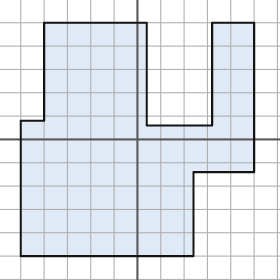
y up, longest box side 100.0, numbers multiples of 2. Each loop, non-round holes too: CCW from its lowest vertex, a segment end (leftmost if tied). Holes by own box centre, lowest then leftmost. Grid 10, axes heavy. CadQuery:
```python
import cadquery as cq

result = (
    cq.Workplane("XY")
    .moveTo(-50.0, -50.0)
    .lineTo(24.0, -50.0)
    .lineTo(24.0, -14.0)
    .lineTo(50.0, -14.0)
    .lineTo(50.0, 50.0)
    .lineTo(32.0, 50.0)
    .lineTo(32.0, 6.0)
    .lineTo(4.0, 6.0)
    .lineTo(4.0, 50.0)
    .lineTo(-40.0, 50.0)
    .lineTo(-40.0, 8.0)
    .lineTo(-50.0, 8.0)
    .close()
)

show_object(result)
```